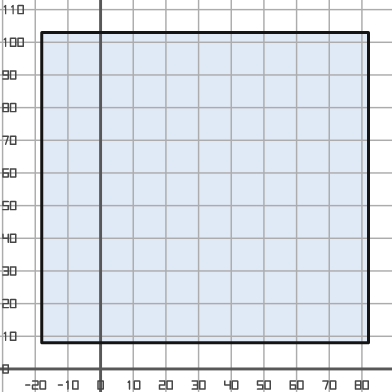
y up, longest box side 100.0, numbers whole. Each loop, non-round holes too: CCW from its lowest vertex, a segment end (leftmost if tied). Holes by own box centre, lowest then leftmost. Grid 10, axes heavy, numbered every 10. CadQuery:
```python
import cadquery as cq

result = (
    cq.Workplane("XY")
    .moveTo(-18.0, 8.0)
    .lineTo(82.0, 8.0)
    .lineTo(82.0, 103.0)
    .lineTo(-18.0, 103.0)
    .close()
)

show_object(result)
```